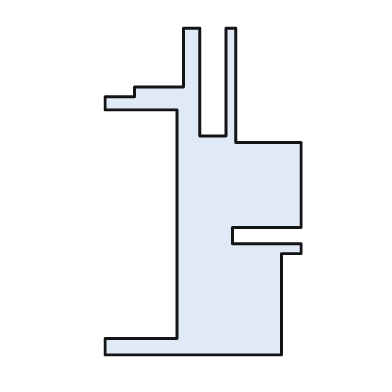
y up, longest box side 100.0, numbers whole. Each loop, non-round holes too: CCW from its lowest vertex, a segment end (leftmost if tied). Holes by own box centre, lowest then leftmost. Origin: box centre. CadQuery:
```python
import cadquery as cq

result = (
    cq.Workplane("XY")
    .moveTo(-30.0, -50.0)
    .lineTo(24.0, -50.0)
    .lineTo(24.0, -19.0)
    .lineTo(30.0, -19.0)
    .lineTo(30.0, -16.0)
    .lineTo(9.0, -16.0)
    .lineTo(9.0, -11.0)
    .lineTo(30.0, -11.0)
    .lineTo(30.0, 15.0)
    .lineTo(10.0, 15.0)
    .lineTo(10.0, 50.0)
    .lineTo(7.0, 50.0)
    .lineTo(7.0, 17.0)
    .lineTo(-1.0, 17.0)
    .lineTo(-1.0, 50.0)
    .lineTo(-6.0, 50.0)
    .lineTo(-6.0, 32.0)
    .lineTo(-21.0, 32.0)
    .lineTo(-21.0, 29.0)
    .lineTo(-30.0, 29.0)
    .lineTo(-30.0, 25.0)
    .lineTo(-8.0, 25.0)
    .lineTo(-8.0, -45.0)
    .lineTo(-30.0, -45.0)
    .close()
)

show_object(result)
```